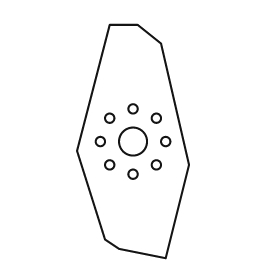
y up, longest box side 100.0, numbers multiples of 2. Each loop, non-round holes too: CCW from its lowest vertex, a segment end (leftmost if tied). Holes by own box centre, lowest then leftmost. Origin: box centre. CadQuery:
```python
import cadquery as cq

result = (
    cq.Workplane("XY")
    .moveTo(14.0, -50.0)
    .lineTo(24.0, -10.0)
    .lineTo(12.0, 42.0)
    .lineTo(2.0, 50.0)
    .lineTo(-10.0, 50.0)
    .lineTo(-24.0, -4.0)
    .lineTo(-12.0, -42.0)
    .lineTo(-6.0, -46.0)
    .close()
    .moveTo(0.0, -14.0)
    .circle(2.0)
    .moveTo(-10.0, -10.0)
    .circle(2.0)
    .moveTo(10.0, -10.0)
    .circle(2.0)
    .moveTo(-14.0, 0.0)
    .circle(2.0)
    .moveTo(0.0, 0.0)
    .circle(6.0)
    .moveTo(14.0, 0.0)
    .circle(2.0)
    .moveTo(-10.0, 10.0)
    .circle(2.0)
    .moveTo(10.0, 10.0)
    .circle(2.0)
    .moveTo(0.0, 14.0)
    .circle(2.0)
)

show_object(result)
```